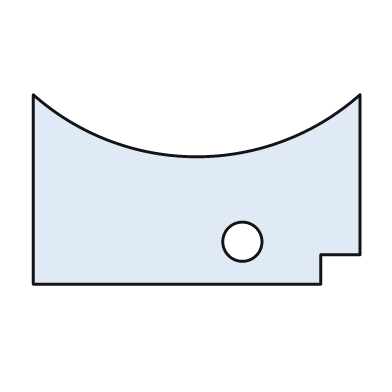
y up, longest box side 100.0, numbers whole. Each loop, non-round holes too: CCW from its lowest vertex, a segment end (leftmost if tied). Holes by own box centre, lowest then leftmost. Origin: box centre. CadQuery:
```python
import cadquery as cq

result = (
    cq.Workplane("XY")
    .moveTo(-50.0, -29.0)
    .lineTo(38.0, -29.0)
    .lineTo(38.0, -20.0)
    .lineTo(50.0, -20.0)
    .lineTo(50.0, 29.0)
    .threePointArc((0.0, 10.0), (-50.0, 29.0))
    .close()
    .moveTo(14.0, -16.0)
    .circle(6.0)
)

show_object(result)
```